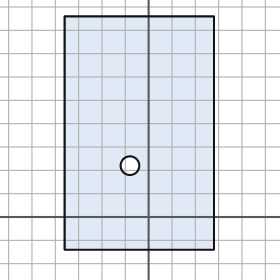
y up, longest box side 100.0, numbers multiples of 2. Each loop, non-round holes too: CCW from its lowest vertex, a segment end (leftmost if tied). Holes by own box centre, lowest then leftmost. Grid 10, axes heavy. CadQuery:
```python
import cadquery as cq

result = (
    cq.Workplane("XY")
    .moveTo(-36.0, -14.0)
    .lineTo(28.0, -14.0)
    .lineTo(28.0, 86.0)
    .lineTo(-36.0, 86.0)
    .close()
    .moveTo(-8.0, 22.0)
    .circle(4.0)
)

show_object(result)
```